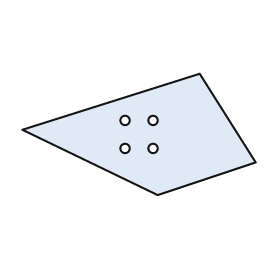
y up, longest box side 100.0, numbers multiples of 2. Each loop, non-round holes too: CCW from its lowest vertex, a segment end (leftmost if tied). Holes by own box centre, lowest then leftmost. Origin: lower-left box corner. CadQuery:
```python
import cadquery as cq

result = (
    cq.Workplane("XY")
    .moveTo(58.0, 0.0)
    .lineTo(100.0, 14.0)
    .lineTo(76.0, 52.0)
    .lineTo(0.0, 28.0)
    .close()
    .moveTo(44.0, 20.0)
    .circle(2.0)
    .moveTo(56.0, 20.0)
    .circle(2.0)
    .moveTo(44.0, 32.0)
    .circle(2.0)
    .moveTo(56.0, 32.0)
    .circle(2.0)
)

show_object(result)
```